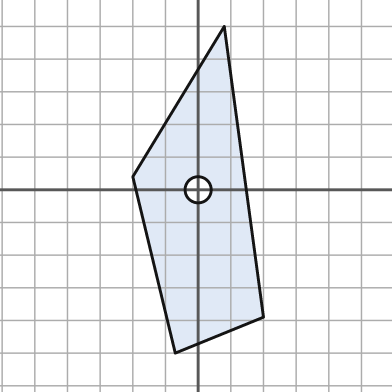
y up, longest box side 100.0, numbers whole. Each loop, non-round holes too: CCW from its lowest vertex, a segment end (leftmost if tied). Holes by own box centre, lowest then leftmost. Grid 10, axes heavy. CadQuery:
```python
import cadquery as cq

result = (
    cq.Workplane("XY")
    .moveTo(-7.0, -50.0)
    .lineTo(20.0, -39.0)
    .lineTo(8.0, 50.0)
    .lineTo(-20.0, 4.0)
    .close()
    .moveTo(0.0, 0.0)
    .circle(4.0)
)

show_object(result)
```